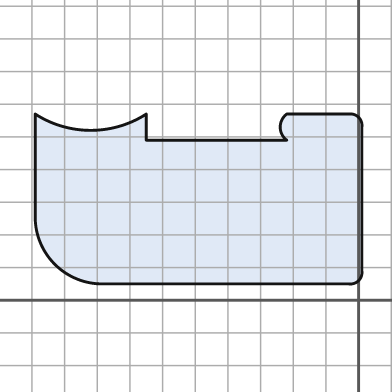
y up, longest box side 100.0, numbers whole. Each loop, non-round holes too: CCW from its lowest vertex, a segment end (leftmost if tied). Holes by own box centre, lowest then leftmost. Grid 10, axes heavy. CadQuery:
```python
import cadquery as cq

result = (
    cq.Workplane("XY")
    .moveTo(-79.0, 5.0)
    .lineTo(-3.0, 5.0)
    .threePointArc((0.0, 6.0), (1.0, 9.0))
    .lineTo(1.0, 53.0)
    .threePointArc((0.0, 56.0), (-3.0, 57.0))
    .lineTo(-22.0, 57.0)
    .threePointArc((-24.0, 53.0), (-22.0, 49.0))
    .lineTo(-65.0, 49.0)
    .lineTo(-65.0, 57.0)
    .threePointArc((-82.0, 52.0), (-99.0, 57.0))
    .lineTo(-99.0, 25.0)
    .threePointArc((-93.0, 11.0), (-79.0, 5.0))
    .close()
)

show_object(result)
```